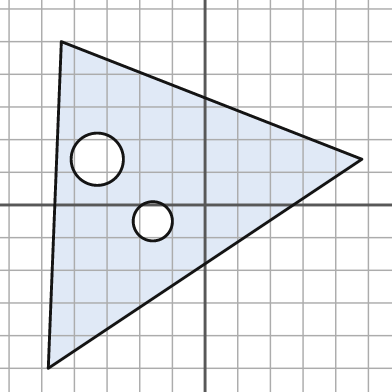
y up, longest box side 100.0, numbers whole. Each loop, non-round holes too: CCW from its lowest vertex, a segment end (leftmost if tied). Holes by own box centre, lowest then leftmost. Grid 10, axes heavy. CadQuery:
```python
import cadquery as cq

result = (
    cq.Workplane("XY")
    .moveTo(-48.0, -50.0)
    .lineTo(48.0, 14.0)
    .lineTo(-44.0, 50.0)
    .close()
    .moveTo(-16.0, -5.0)
    .circle(6.0)
    .moveTo(-33.0, 14.0)
    .circle(8.0)
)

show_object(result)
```